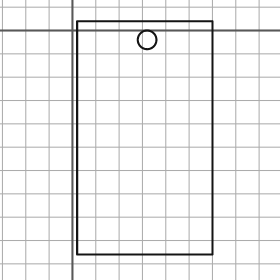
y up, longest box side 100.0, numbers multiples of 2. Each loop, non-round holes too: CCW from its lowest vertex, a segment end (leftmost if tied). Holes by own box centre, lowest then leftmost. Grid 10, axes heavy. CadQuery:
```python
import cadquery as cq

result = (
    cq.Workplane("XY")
    .moveTo(2.0, -96.0)
    .lineTo(60.0, -96.0)
    .lineTo(60.0, 4.0)
    .lineTo(2.0, 4.0)
    .close()
    .moveTo(32.0, -4.0)
    .circle(4.0)
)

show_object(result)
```